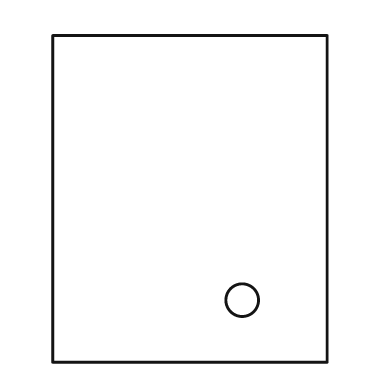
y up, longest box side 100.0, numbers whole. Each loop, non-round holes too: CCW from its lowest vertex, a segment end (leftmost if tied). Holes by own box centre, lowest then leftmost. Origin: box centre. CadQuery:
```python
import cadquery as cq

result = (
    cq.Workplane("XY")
    .moveTo(-42.0, -50.0)
    .lineTo(42.0, -50.0)
    .lineTo(42.0, 50.0)
    .lineTo(-42.0, 50.0)
    .close()
    .moveTo(16.0, -31.0)
    .circle(5.0)
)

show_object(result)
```